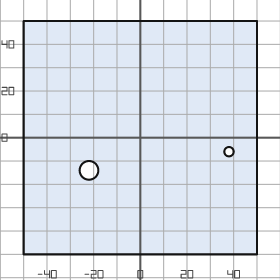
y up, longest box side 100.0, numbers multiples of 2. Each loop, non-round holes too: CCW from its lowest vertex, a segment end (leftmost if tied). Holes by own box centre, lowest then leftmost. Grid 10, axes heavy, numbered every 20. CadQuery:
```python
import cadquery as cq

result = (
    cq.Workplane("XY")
    .moveTo(-50.0, -50.0)
    .lineTo(50.0, -50.0)
    .lineTo(50.0, 50.0)
    .lineTo(-50.0, 50.0)
    .close()
    .moveTo(-22.0, -14.0)
    .circle(4.0)
    .moveTo(38.0, -6.0)
    .circle(2.0)
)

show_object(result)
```